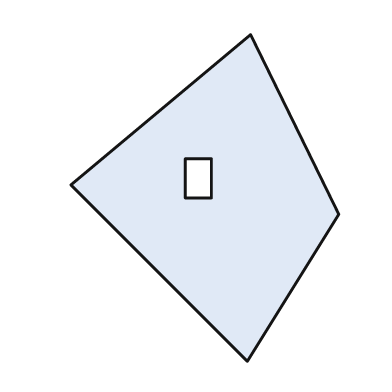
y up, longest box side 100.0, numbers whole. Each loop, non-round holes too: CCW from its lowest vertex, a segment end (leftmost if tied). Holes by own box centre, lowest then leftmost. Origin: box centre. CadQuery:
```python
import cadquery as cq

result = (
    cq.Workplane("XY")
    .moveTo(13.0, -50.0)
    .lineTo(41.0, -5.0)
    .lineTo(14.0, 50.0)
    .lineTo(-41.0, 4.0)
    .close()
    .moveTo(-6.0, 0.0)
    .lineTo(2.0, 0.0)
    .lineTo(2.0, 12.0)
    .lineTo(-6.0, 12.0)
    .close()
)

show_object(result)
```